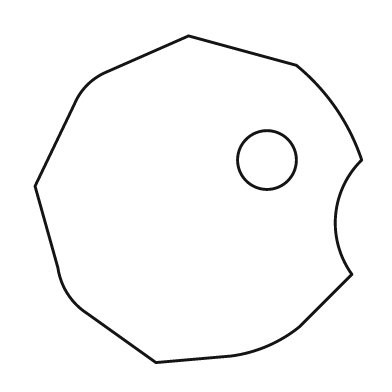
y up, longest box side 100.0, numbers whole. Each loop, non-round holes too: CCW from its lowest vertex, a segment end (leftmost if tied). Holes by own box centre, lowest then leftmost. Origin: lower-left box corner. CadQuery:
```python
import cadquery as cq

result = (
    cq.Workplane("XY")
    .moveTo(37.0, 0.0)
    .lineTo(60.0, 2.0)
    .threePointArc((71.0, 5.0), (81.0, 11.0))
    .lineTo(97.0, 27.0)
    .threePointArc((92.0, 45.0), (100.0, 62.0))
    .threePointArc((92.0, 78.0), (80.0, 91.0))
    .lineTo(47.0, 100.0)
    .lineTo(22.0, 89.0)
    .threePointArc((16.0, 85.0), (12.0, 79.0))
    .lineTo(0.0, 54.0)
    .lineTo(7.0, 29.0)
    .threePointArc((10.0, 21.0), (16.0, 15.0))
    .close()
    .moveTo(71.0, 62.0)
    .circle(9.0)
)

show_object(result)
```